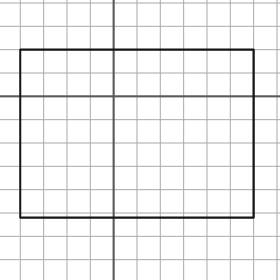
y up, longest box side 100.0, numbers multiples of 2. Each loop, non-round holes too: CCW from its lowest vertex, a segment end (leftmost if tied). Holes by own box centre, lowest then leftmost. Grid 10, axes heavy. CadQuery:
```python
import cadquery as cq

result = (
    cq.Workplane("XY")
    .moveTo(-40.0, -52.0)
    .lineTo(60.0, -52.0)
    .lineTo(60.0, 20.0)
    .lineTo(-40.0, 20.0)
    .close()
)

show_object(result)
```